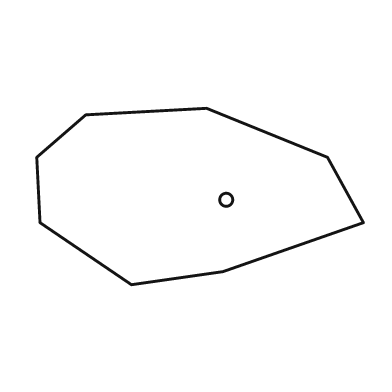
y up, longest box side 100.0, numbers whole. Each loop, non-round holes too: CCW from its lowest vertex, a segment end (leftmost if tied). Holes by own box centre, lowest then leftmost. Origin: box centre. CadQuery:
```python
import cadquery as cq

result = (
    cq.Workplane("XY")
    .moveTo(-21.0, -27.0)
    .lineTo(7.0, -23.0)
    .lineTo(50.0, -8.0)
    .lineTo(39.0, 12.0)
    .lineTo(2.0, 27.0)
    .lineTo(-35.0, 25.0)
    .lineTo(-50.0, 12.0)
    .lineTo(-49.0, -8.0)
    .close()
    .moveTo(8.0, -1.0)
    .circle(2.0)
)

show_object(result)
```